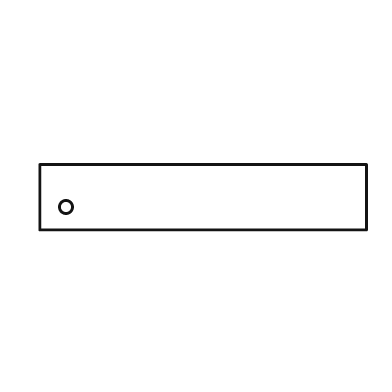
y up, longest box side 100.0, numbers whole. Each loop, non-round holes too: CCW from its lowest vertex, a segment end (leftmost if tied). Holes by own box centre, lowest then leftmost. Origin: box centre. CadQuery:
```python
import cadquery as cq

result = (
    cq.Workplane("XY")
    .moveTo(-50.0, -10.0)
    .lineTo(50.0, -10.0)
    .lineTo(50.0, 10.0)
    .lineTo(-50.0, 10.0)
    .close()
    .moveTo(-42.0, -3.0)
    .circle(2.0)
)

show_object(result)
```